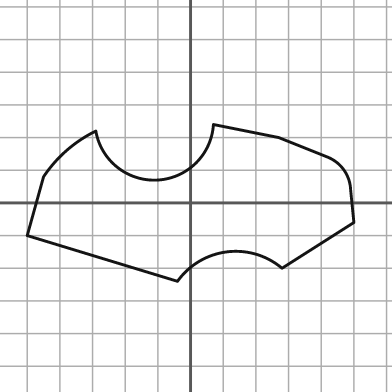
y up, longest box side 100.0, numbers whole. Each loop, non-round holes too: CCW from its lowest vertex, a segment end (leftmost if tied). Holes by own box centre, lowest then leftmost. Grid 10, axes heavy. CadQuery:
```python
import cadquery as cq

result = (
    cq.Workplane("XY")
    .moveTo(-4.0, -24.0)
    .threePointArc((11.0, -15.0), (28.0, -20.0))
    .lineTo(50.0, -6.0)
    .lineTo(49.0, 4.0)
    .threePointArc((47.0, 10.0), (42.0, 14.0))
    .lineTo(27.0, 20.0)
    .lineTo(7.0, 24.0)
    .threePointArc((-10.0, 7.0), (-29.0, 22.0))
    .threePointArc((-38.0, 16.0), (-45.0, 8.0))
    .lineTo(-50.0, -10.0)
    .close()
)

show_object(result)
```